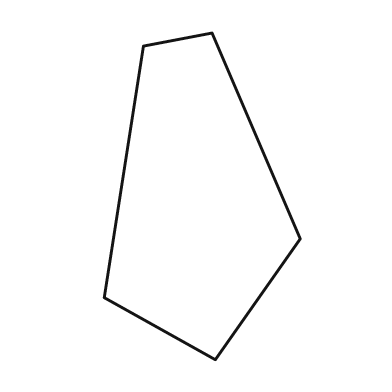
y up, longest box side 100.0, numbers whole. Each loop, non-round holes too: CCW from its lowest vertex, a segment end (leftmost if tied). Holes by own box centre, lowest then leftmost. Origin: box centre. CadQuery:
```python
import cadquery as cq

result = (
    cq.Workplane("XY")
    .moveTo(4.0, -50.0)
    .lineTo(30.0, -13.0)
    .lineTo(3.0, 50.0)
    .lineTo(-18.0, 46.0)
    .lineTo(-30.0, -31.0)
    .close()
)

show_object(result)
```